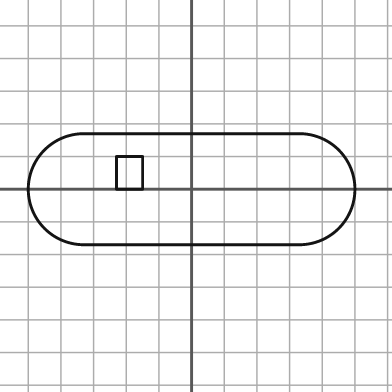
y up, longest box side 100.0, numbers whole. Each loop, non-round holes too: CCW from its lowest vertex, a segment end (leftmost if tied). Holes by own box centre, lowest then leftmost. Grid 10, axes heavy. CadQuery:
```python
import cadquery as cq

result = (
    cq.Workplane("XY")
    .moveTo(-33.0, -17.0)
    .lineTo(33.0, -17.0)
    .threePointArc((50.0, 0.0), (33.0, 17.0))
    .lineTo(-33.0, 17.0)
    .threePointArc((-50.0, 0.0), (-33.0, -17.0))
    .close()
    .moveTo(-23.0, 0.0)
    .lineTo(-15.0, 0.0)
    .lineTo(-15.0, 10.0)
    .lineTo(-23.0, 10.0)
    .close()
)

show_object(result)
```